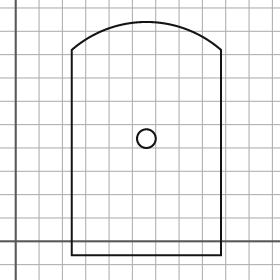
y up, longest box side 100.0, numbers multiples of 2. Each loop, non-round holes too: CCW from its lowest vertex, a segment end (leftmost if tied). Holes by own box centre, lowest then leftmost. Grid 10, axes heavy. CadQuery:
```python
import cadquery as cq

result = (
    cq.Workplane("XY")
    .moveTo(24.0, -6.0)
    .lineTo(88.0, -6.0)
    .lineTo(88.0, 82.0)
    .threePointArc((56.0, 94.0), (24.0, 82.0))
    .close()
    .moveTo(56.0, 44.0)
    .circle(4.0)
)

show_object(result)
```